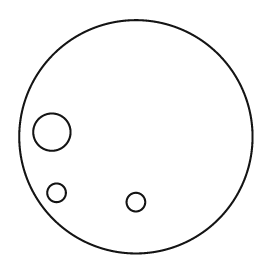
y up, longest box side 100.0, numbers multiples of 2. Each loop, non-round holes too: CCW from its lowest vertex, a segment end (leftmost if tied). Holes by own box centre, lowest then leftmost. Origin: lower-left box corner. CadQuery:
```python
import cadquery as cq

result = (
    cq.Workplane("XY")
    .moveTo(50.0, 50.0)
    .circle(50.0)
    .moveTo(50.0, 22.0)
    .circle(4.0)
    .moveTo(16.0, 26.0)
    .circle(4.0)
    .moveTo(14.0, 52.0)
    .circle(8.0)
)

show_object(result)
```